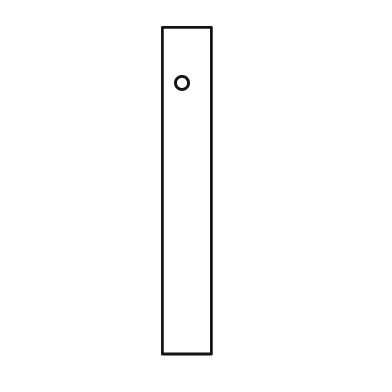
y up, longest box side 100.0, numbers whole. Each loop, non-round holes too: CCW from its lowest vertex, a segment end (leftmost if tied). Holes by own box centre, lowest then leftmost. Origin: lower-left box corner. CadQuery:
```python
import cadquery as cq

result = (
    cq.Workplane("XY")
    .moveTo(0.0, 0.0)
    .lineTo(15.0, 0.0)
    .lineTo(15.0, 100.0)
    .lineTo(0.0, 100.0)
    .close()
    .moveTo(6.0, 83.0)
    .circle(2.0)
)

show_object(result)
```